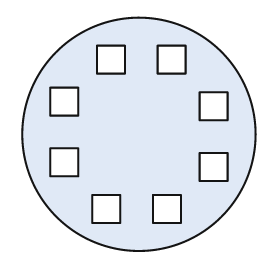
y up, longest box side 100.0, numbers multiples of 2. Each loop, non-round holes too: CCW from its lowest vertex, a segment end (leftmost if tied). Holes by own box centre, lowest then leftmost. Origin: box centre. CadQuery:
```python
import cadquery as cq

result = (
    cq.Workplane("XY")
    .moveTo(0.0, 0.0)
    .circle(50.0)
    .moveTo(-20.0, -38.0)
    .lineTo(-8.0, -38.0)
    .lineTo(-8.0, -26.0)
    .lineTo(-20.0, -26.0)
    .close()
    .moveTo(6.0, -38.0)
    .lineTo(18.0, -38.0)
    .lineTo(18.0, -26.0)
    .lineTo(6.0, -26.0)
    .close()
    .moveTo(26.0, -20.0)
    .lineTo(38.0, -20.0)
    .lineTo(38.0, -8.0)
    .lineTo(26.0, -8.0)
    .close()
    .moveTo(-38.0, -18.0)
    .lineTo(-26.0, -18.0)
    .lineTo(-26.0, -6.0)
    .lineTo(-38.0, -6.0)
    .close()
    .moveTo(26.0, 6.0)
    .lineTo(38.0, 6.0)
    .lineTo(38.0, 18.0)
    .lineTo(26.0, 18.0)
    .close()
    .moveTo(-38.0, 8.0)
    .lineTo(-26.0, 8.0)
    .lineTo(-26.0, 20.0)
    .lineTo(-38.0, 20.0)
    .close()
    .moveTo(-18.0, 26.0)
    .lineTo(-6.0, 26.0)
    .lineTo(-6.0, 38.0)
    .lineTo(-18.0, 38.0)
    .close()
    .moveTo(8.0, 26.0)
    .lineTo(20.0, 26.0)
    .lineTo(20.0, 38.0)
    .lineTo(8.0, 38.0)
    .close()
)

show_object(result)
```